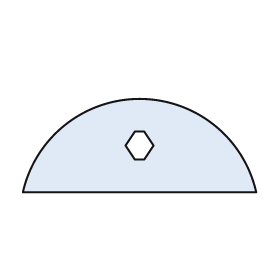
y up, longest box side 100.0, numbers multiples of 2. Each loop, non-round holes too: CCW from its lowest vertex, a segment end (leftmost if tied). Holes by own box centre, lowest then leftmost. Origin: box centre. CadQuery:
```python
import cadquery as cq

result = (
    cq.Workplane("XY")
    .moveTo(-50.0, -20.0)
    .lineTo(50.0, -20.0)
    .threePointArc((0.0, 20.0), (-50.0, -20.0))
    .close()
    .moveTo(-2.0, -6.0)
    .lineTo(2.0, -6.0)
    .lineTo(6.0, 0.0)
    .lineTo(2.0, 6.0)
    .lineTo(-2.0, 6.0)
    .lineTo(-6.0, 0.0)
    .close()
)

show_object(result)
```